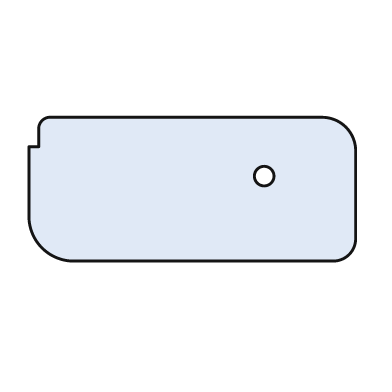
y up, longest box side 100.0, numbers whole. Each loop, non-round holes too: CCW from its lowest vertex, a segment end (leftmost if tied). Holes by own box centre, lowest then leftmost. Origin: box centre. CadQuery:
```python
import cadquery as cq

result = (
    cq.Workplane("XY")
    .moveTo(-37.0, -22.0)
    .lineTo(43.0, -22.0)
    .threePointArc((48.0, -20.0), (50.0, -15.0))
    .lineTo(50.0, 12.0)
    .threePointArc((47.0, 19.0), (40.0, 22.0))
    .lineTo(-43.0, 22.0)
    .threePointArc((-46.0, 21.0), (-47.0, 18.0))
    .lineTo(-47.0, 13.0)
    .lineTo(-50.0, 13.0)
    .lineTo(-50.0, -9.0)
    .threePointArc((-46.0, -18.0), (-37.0, -22.0))
    .close()
    .moveTo(22.0, 4.0)
    .circle(3.0)
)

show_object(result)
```